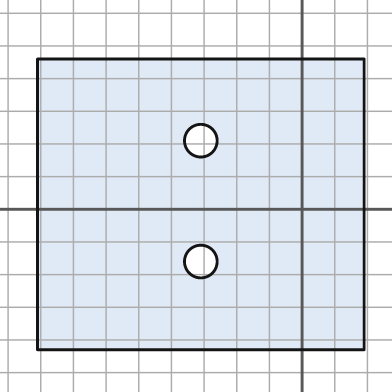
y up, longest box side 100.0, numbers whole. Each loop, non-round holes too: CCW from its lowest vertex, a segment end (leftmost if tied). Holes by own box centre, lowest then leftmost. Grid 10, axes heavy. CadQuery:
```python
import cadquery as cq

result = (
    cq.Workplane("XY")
    .moveTo(-81.0, -43.0)
    .lineTo(19.0, -43.0)
    .lineTo(19.0, 46.0)
    .lineTo(-81.0, 46.0)
    .close()
    .moveTo(-31.0, -16.0)
    .circle(5.0)
    .moveTo(-31.0, 21.0)
    .circle(5.0)
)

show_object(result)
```